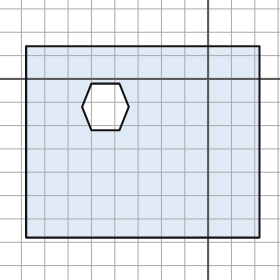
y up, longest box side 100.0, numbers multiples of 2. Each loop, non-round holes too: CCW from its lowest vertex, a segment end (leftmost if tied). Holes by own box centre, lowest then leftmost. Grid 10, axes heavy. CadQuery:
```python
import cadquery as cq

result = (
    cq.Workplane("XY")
    .moveTo(-78.0, -68.0)
    .lineTo(22.0, -68.0)
    .lineTo(22.0, 14.0)
    .lineTo(-78.0, 14.0)
    .close()
    .moveTo(-50.0, -22.0)
    .lineTo(-38.0, -22.0)
    .lineTo(-34.0, -12.0)
    .lineTo(-38.0, -2.0)
    .lineTo(-50.0, -2.0)
    .lineTo(-54.0, -12.0)
    .close()
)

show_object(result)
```